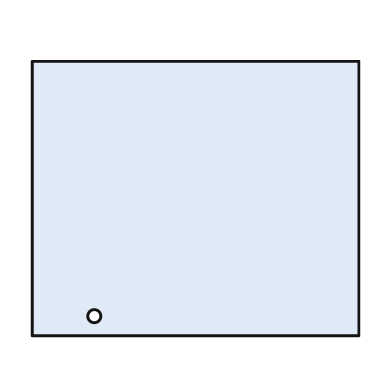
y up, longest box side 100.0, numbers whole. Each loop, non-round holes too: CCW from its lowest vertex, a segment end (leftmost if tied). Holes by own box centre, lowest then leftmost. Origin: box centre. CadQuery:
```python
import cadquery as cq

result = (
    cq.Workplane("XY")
    .moveTo(-50.0, -42.0)
    .lineTo(50.0, -42.0)
    .lineTo(50.0, 42.0)
    .lineTo(-50.0, 42.0)
    .close()
    .moveTo(-31.0, -36.0)
    .circle(2.0)
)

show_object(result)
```